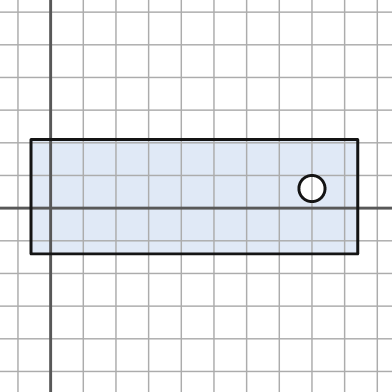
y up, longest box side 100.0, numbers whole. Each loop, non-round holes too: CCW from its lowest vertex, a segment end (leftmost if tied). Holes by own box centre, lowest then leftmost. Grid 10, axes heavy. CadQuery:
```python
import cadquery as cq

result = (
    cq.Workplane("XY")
    .moveTo(-6.0, -14.0)
    .lineTo(94.0, -14.0)
    .lineTo(94.0, 21.0)
    .lineTo(-6.0, 21.0)
    .close()
    .moveTo(80.0, 6.0)
    .circle(4.0)
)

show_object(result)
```